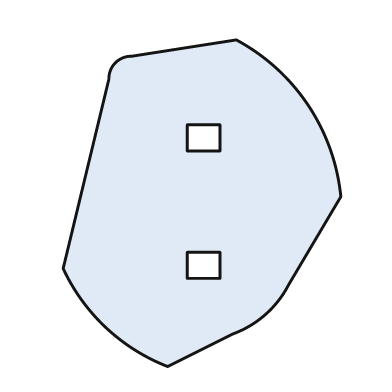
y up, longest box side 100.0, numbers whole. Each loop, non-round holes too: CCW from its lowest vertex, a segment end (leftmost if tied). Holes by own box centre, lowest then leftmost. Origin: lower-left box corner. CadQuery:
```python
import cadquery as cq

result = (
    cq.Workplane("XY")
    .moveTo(32.0, 0.0)
    .lineTo(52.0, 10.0)
    .threePointArc((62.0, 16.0), (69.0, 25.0))
    .lineTo(85.0, 52.0)
    .threePointArc((75.0, 80.0), (53.0, 100.0))
    .lineTo(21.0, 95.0)
    .threePointArc((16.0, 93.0), (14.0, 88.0))
    .lineTo(0.0, 30.0)
    .threePointArc((13.0, 12.0), (32.0, 0.0))
    .close()
    .moveTo(38.0, 27.0)
    .lineTo(48.0, 27.0)
    .lineTo(48.0, 35.0)
    .lineTo(38.0, 35.0)
    .close()
    .moveTo(38.0, 66.0)
    .lineTo(48.0, 66.0)
    .lineTo(48.0, 74.0)
    .lineTo(38.0, 74.0)
    .close()
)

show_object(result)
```